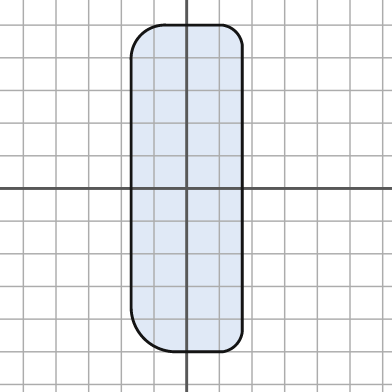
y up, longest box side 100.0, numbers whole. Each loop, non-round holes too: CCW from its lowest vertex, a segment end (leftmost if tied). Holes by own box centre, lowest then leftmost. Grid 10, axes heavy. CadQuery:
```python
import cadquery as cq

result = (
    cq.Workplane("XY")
    .moveTo(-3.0, -50.0)
    .lineTo(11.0, -50.0)
    .threePointArc((15.0, -48.0), (17.0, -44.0))
    .lineTo(17.0, 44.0)
    .threePointArc((15.0, 48.0), (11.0, 50.0))
    .lineTo(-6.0, 50.0)
    .threePointArc((-14.0, 47.0), (-17.0, 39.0))
    .lineTo(-17.0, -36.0)
    .threePointArc((-13.0, -46.0), (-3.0, -50.0))
    .close()
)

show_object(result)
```